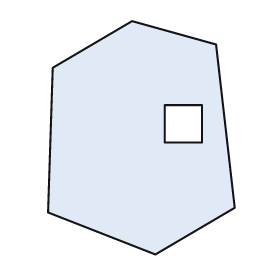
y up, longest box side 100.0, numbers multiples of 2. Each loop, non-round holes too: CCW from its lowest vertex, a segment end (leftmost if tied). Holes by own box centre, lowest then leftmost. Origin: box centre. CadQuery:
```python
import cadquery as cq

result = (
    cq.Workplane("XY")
    .moveTo(6.0, -50.0)
    .lineTo(40.0, -30.0)
    .lineTo(32.0, 40.0)
    .lineTo(-4.0, 50.0)
    .lineTo(-38.0, 30.0)
    .lineTo(-40.0, -32.0)
    .close()
    .moveTo(10.0, -2.0)
    .lineTo(26.0, -2.0)
    .lineTo(26.0, 14.0)
    .lineTo(10.0, 14.0)
    .close()
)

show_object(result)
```